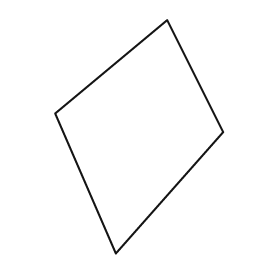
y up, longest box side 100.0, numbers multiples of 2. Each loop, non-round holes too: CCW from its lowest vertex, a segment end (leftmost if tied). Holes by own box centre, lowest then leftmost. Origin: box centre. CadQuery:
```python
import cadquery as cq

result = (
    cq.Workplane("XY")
    .moveTo(-10.0, -50.0)
    .lineTo(36.0, 2.0)
    .lineTo(12.0, 50.0)
    .lineTo(-36.0, 10.0)
    .close()
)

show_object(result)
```